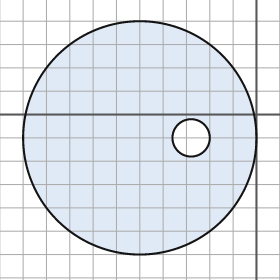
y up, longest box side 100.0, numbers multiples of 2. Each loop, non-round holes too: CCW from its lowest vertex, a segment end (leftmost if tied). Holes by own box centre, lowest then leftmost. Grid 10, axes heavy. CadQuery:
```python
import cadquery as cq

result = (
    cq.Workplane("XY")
    .moveTo(-50.0, -10.0)
    .circle(50.0)
    .moveTo(-28.0, -10.0)
    .circle(8.0)
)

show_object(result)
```